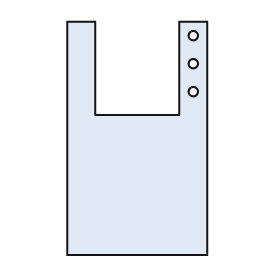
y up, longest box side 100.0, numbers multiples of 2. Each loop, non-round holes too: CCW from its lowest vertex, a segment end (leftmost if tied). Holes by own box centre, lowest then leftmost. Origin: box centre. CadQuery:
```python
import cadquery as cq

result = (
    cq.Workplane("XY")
    .moveTo(-30.0, -50.0)
    .lineTo(30.0, -50.0)
    .lineTo(30.0, 50.0)
    .lineTo(18.0, 50.0)
    .lineTo(18.0, 10.0)
    .lineTo(-18.0, 10.0)
    .lineTo(-18.0, 50.0)
    .lineTo(-30.0, 50.0)
    .close()
    .moveTo(24.0, 20.0)
    .circle(2.0)
    .moveTo(24.0, 32.0)
    .circle(2.0)
    .moveTo(24.0, 44.0)
    .circle(2.0)
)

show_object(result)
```